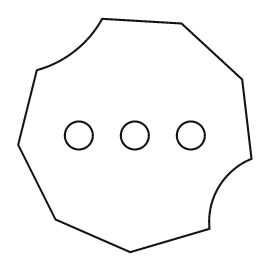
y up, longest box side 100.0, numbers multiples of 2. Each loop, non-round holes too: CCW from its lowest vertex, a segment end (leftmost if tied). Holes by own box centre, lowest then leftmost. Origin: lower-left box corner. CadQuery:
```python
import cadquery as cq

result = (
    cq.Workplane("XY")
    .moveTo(48.0, 0.0)
    .lineTo(82.0, 10.0)
    .threePointArc((86.0, 28.0), (100.0, 40.0))
    .lineTo(96.0, 74.0)
    .lineTo(70.0, 98.0)
    .lineTo(36.0, 100.0)
    .threePointArc((24.0, 86.0), (8.0, 78.0))
    .lineTo(0.0, 46.0)
    .lineTo(16.0, 14.0)
    .close()
    .moveTo(26.0, 50.0)
    .circle(6.0)
    .moveTo(50.0, 50.0)
    .circle(6.0)
    .moveTo(74.0, 50.0)
    .circle(6.0)
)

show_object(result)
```